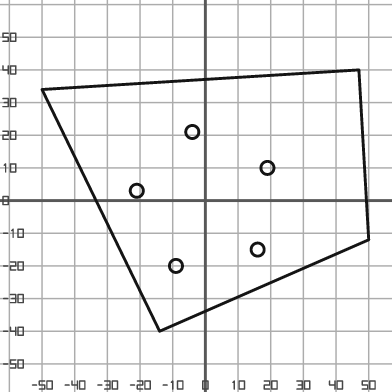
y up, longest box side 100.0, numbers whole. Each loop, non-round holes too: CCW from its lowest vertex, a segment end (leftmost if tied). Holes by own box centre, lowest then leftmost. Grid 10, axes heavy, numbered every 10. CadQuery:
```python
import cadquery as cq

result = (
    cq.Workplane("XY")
    .moveTo(-14.0, -40.0)
    .lineTo(50.0, -12.0)
    .lineTo(47.0, 40.0)
    .lineTo(-50.0, 34.0)
    .close()
    .moveTo(-9.0, -20.0)
    .circle(2.0)
    .moveTo(16.0, -15.0)
    .circle(2.0)
    .moveTo(-21.0, 3.0)
    .circle(2.0)
    .moveTo(19.0, 10.0)
    .circle(2.0)
    .moveTo(-4.0, 21.0)
    .circle(2.0)
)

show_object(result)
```